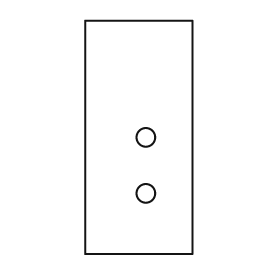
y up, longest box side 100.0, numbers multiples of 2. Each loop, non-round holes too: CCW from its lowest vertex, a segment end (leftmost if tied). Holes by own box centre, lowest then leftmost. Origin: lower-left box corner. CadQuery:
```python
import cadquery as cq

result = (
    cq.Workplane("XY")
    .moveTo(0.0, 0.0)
    .lineTo(46.0, 0.0)
    .lineTo(46.0, 100.0)
    .lineTo(0.0, 100.0)
    .close()
    .moveTo(26.0, 26.0)
    .circle(4.0)
    .moveTo(26.0, 50.0)
    .circle(4.0)
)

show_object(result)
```